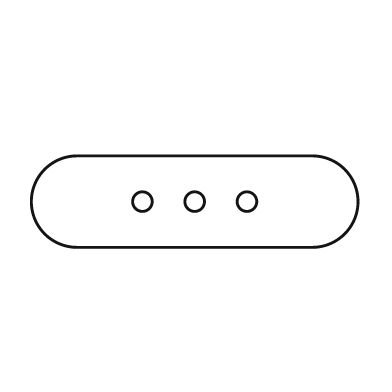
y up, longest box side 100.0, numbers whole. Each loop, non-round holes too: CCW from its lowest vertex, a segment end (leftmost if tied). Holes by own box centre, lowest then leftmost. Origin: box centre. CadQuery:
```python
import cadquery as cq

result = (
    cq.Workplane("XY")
    .moveTo(-36.0, -14.0)
    .lineTo(36.0, -14.0)
    .threePointArc((50.0, 0.0), (36.0, 14.0))
    .lineTo(-36.0, 14.0)
    .threePointArc((-50.0, 0.0), (-36.0, -14.0))
    .close()
    .moveTo(-16.0, 0.0)
    .circle(3.0)
    .moveTo(0.0, 0.0)
    .circle(3.0)
    .moveTo(16.0, 0.0)
    .circle(3.0)
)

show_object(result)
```